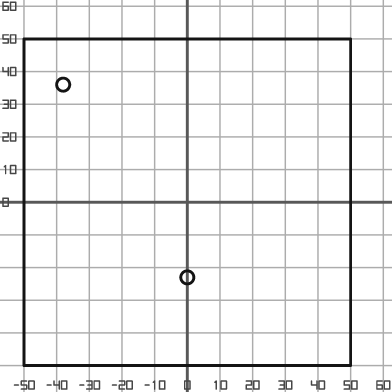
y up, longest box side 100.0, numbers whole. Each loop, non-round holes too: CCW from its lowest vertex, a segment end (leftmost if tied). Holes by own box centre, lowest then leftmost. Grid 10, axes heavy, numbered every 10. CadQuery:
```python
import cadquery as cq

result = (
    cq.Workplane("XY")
    .moveTo(-50.0, -50.0)
    .lineTo(50.0, -50.0)
    .lineTo(50.0, 50.0)
    .lineTo(-50.0, 50.0)
    .close()
    .moveTo(0.0, -23.0)
    .circle(2.0)
    .moveTo(-38.0, 36.0)
    .circle(2.0)
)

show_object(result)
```